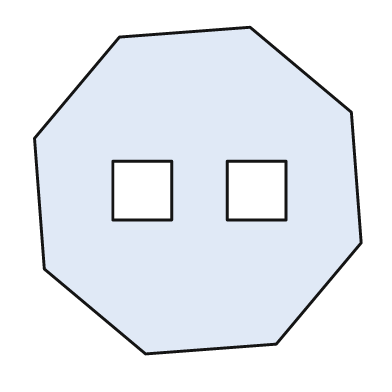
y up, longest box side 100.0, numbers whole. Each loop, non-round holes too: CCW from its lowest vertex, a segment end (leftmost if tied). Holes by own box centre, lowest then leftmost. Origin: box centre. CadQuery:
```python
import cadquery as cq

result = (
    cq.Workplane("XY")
    .moveTo(-16.0, -50.0)
    .lineTo(24.0, -47.0)
    .lineTo(50.0, -16.0)
    .lineTo(47.0, 24.0)
    .lineTo(16.0, 50.0)
    .lineTo(-24.0, 47.0)
    .lineTo(-50.0, 16.0)
    .lineTo(-47.0, -24.0)
    .close()
    .moveTo(-26.0, -9.0)
    .lineTo(-8.0, -9.0)
    .lineTo(-8.0, 9.0)
    .lineTo(-26.0, 9.0)
    .close()
    .moveTo(9.0, -9.0)
    .lineTo(27.0, -9.0)
    .lineTo(27.0, 9.0)
    .lineTo(9.0, 9.0)
    .close()
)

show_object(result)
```